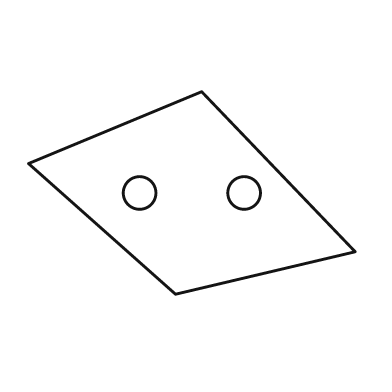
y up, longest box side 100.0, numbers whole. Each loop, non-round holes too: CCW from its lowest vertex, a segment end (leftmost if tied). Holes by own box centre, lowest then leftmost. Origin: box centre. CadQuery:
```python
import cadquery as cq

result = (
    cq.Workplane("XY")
    .moveTo(-5.0, -31.0)
    .lineTo(50.0, -18.0)
    .lineTo(3.0, 31.0)
    .lineTo(-50.0, 9.0)
    .close()
    .moveTo(-16.0, 0.0)
    .circle(5.0)
    .moveTo(16.0, 0.0)
    .circle(5.0)
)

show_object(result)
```